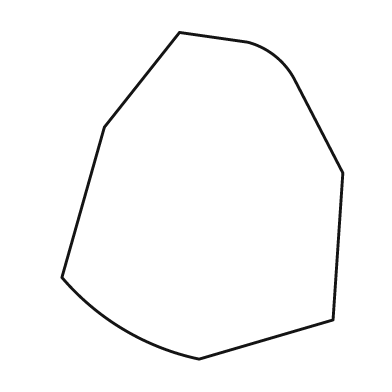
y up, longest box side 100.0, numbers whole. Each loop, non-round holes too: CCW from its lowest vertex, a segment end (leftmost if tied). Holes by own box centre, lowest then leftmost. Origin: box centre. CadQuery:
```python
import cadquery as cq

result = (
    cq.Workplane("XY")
    .moveTo(-1.0, -50.0)
    .lineTo(40.0, -38.0)
    .lineTo(43.0, 7.0)
    .lineTo(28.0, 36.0)
    .threePointArc((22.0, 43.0), (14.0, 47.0))
    .lineTo(-7.0, 50.0)
    .lineTo(-30.0, 21.0)
    .lineTo(-43.0, -25.0)
    .threePointArc((-24.0, -41.0), (-1.0, -50.0))
    .close()
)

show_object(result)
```